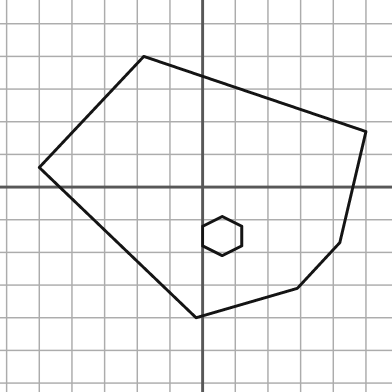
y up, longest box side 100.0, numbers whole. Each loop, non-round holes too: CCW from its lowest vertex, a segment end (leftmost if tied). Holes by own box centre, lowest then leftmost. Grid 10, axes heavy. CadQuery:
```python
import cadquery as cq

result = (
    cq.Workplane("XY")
    .moveTo(-2.0, -40.0)
    .lineTo(29.0, -31.0)
    .lineTo(42.0, -17.0)
    .lineTo(50.0, 17.0)
    .lineTo(-18.0, 40.0)
    .lineTo(-50.0, 6.0)
    .close()
    .moveTo(6.0, -21.0)
    .lineTo(12.0, -18.0)
    .lineTo(12.0, -12.0)
    .lineTo(6.0, -9.0)
    .lineTo(0.0, -12.0)
    .lineTo(0.0, -18.0)
    .close()
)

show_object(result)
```